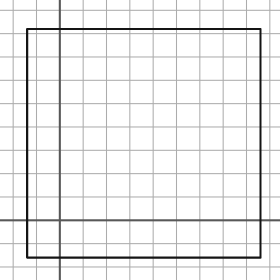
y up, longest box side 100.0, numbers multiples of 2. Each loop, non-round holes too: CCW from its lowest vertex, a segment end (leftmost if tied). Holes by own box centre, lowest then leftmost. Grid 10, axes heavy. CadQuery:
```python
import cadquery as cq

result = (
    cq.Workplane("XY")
    .moveTo(-14.0, -16.0)
    .lineTo(86.0, -16.0)
    .lineTo(86.0, 82.0)
    .lineTo(-14.0, 82.0)
    .close()
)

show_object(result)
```